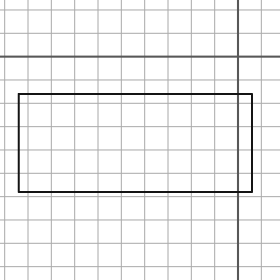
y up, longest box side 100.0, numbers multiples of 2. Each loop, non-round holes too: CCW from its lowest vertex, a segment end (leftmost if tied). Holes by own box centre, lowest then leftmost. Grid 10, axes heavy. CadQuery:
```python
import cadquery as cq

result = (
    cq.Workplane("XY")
    .moveTo(-94.0, -58.0)
    .lineTo(6.0, -58.0)
    .lineTo(6.0, -16.0)
    .lineTo(-94.0, -16.0)
    .close()
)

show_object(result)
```